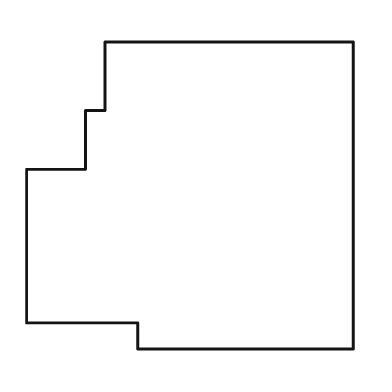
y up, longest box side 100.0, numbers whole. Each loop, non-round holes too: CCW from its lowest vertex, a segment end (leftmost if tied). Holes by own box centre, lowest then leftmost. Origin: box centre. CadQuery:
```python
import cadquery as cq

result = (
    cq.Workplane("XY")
    .moveTo(-16.0, -47.0)
    .lineTo(50.0, -47.0)
    .lineTo(50.0, 47.0)
    .lineTo(-26.0, 47.0)
    .lineTo(-26.0, 26.0)
    .lineTo(-32.0, 26.0)
    .lineTo(-32.0, 8.0)
    .lineTo(-50.0, 8.0)
    .lineTo(-50.0, -39.0)
    .lineTo(-16.0, -39.0)
    .close()
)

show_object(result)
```